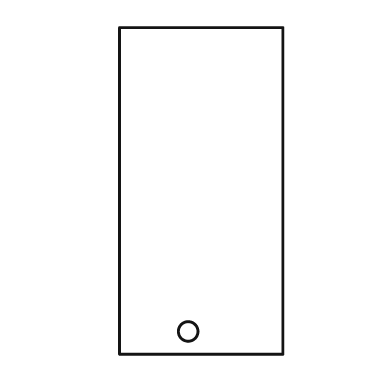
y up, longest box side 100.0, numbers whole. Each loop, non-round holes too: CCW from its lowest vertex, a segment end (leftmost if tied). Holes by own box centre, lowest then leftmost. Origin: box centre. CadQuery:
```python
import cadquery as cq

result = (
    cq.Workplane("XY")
    .moveTo(-25.0, -50.0)
    .lineTo(25.0, -50.0)
    .lineTo(25.0, 50.0)
    .lineTo(-25.0, 50.0)
    .close()
    .moveTo(-4.0, -43.0)
    .circle(3.0)
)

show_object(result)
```